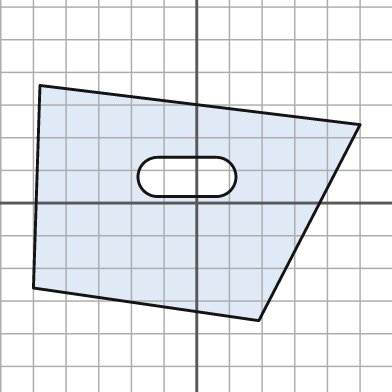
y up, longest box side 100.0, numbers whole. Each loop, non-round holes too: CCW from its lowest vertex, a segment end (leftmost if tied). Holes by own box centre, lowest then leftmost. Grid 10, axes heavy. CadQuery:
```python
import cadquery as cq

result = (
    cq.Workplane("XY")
    .moveTo(19.0, -36.0)
    .lineTo(50.0, 24.0)
    .lineTo(-48.0, 36.0)
    .lineTo(-50.0, -26.0)
    .close()
    .moveTo(-12.0, 2.0)
    .lineTo(6.0, 2.0)
    .threePointArc((12.0, 8.0), (6.0, 14.0))
    .lineTo(-12.0, 14.0)
    .threePointArc((-18.0, 8.0), (-12.0, 2.0))
    .close()
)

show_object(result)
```